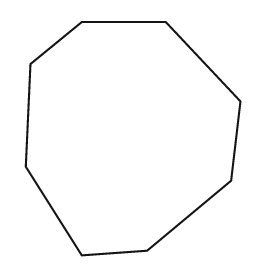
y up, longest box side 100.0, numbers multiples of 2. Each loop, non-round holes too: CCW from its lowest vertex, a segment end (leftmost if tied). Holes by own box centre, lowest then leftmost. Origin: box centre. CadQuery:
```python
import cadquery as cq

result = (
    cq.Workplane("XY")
    .moveTo(-22.0, -50.0)
    .lineTo(6.0, -48.0)
    .lineTo(42.0, -18.0)
    .lineTo(46.0, 16.0)
    .lineTo(14.0, 50.0)
    .lineTo(-22.0, 50.0)
    .lineTo(-44.0, 32.0)
    .lineTo(-46.0, -12.0)
    .close()
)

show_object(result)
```